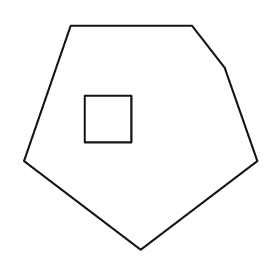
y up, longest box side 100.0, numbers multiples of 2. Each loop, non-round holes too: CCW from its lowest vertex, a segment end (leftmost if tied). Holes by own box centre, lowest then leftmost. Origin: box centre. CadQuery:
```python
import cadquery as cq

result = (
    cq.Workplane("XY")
    .moveTo(0.0, -48.0)
    .lineTo(50.0, -10.0)
    .lineTo(36.0, 30.0)
    .lineTo(22.0, 48.0)
    .lineTo(-30.0, 48.0)
    .lineTo(-50.0, -10.0)
    .close()
    .moveTo(-24.0, -2.0)
    .lineTo(-4.0, -2.0)
    .lineTo(-4.0, 18.0)
    .lineTo(-24.0, 18.0)
    .close()
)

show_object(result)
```